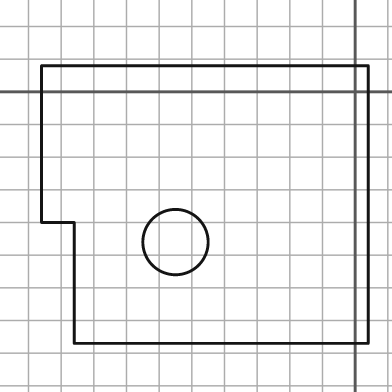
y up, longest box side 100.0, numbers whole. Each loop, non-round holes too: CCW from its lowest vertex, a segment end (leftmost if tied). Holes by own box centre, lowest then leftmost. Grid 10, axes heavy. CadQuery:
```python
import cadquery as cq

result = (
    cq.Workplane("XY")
    .moveTo(-86.0, -77.0)
    .lineTo(4.0, -77.0)
    .lineTo(4.0, 8.0)
    .lineTo(-96.0, 8.0)
    .lineTo(-96.0, -40.0)
    .lineTo(-86.0, -40.0)
    .close()
    .moveTo(-55.0, -46.0)
    .circle(10.0)
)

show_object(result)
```